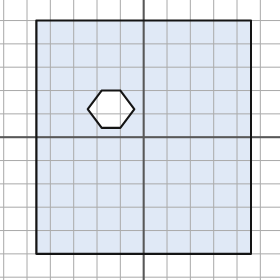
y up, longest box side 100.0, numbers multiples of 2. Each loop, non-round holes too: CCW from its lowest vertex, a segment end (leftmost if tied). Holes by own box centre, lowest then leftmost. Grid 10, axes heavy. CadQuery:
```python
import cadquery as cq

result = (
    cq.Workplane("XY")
    .moveTo(-46.0, -50.0)
    .lineTo(46.0, -50.0)
    .lineTo(46.0, 50.0)
    .lineTo(-46.0, 50.0)
    .close()
    .moveTo(-18.0, 4.0)
    .lineTo(-10.0, 4.0)
    .lineTo(-4.0, 12.0)
    .lineTo(-10.0, 20.0)
    .lineTo(-18.0, 20.0)
    .lineTo(-24.0, 12.0)
    .close()
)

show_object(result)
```